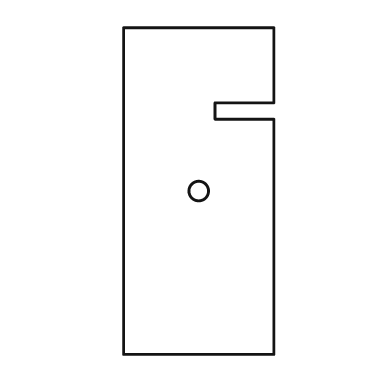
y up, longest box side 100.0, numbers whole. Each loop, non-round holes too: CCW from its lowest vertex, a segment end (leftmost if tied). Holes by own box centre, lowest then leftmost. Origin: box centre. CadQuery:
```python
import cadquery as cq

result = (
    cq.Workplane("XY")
    .moveTo(-23.0, -50.0)
    .lineTo(23.0, -50.0)
    .lineTo(23.0, 22.0)
    .lineTo(5.0, 22.0)
    .lineTo(5.0, 27.0)
    .lineTo(23.0, 27.0)
    .lineTo(23.0, 50.0)
    .lineTo(-23.0, 50.0)
    .close()
    .moveTo(0.0, 0.0)
    .circle(3.0)
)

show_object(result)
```